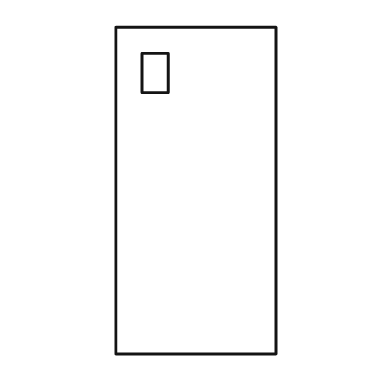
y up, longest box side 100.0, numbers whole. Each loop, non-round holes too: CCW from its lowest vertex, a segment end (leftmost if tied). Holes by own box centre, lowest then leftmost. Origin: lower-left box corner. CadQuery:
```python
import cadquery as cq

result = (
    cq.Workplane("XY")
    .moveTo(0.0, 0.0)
    .lineTo(49.0, 0.0)
    .lineTo(49.0, 100.0)
    .lineTo(0.0, 100.0)
    .close()
    .moveTo(8.0, 80.0)
    .lineTo(16.0, 80.0)
    .lineTo(16.0, 92.0)
    .lineTo(8.0, 92.0)
    .close()
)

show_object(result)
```